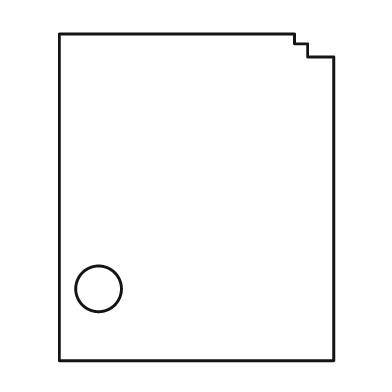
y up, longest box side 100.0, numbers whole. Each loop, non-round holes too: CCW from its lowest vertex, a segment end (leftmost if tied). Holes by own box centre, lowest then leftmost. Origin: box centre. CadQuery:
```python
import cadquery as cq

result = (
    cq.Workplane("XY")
    .moveTo(-42.0, -50.0)
    .lineTo(42.0, -50.0)
    .lineTo(42.0, 43.0)
    .lineTo(34.0, 43.0)
    .lineTo(34.0, 47.0)
    .lineTo(30.0, 47.0)
    .lineTo(30.0, 50.0)
    .lineTo(-42.0, 50.0)
    .close()
    .moveTo(-30.0, -28.0)
    .circle(7.0)
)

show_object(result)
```